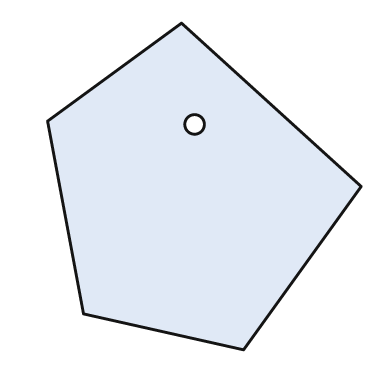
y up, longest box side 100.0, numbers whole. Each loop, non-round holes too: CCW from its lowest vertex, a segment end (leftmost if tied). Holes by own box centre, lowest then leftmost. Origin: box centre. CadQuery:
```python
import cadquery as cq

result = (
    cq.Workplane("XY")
    .moveTo(12.0, -50.0)
    .lineTo(48.0, 0.0)
    .lineTo(-7.0, 50.0)
    .lineTo(-48.0, 20.0)
    .lineTo(-37.0, -39.0)
    .close()
    .moveTo(-3.0, 19.0)
    .circle(3.0)
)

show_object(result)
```